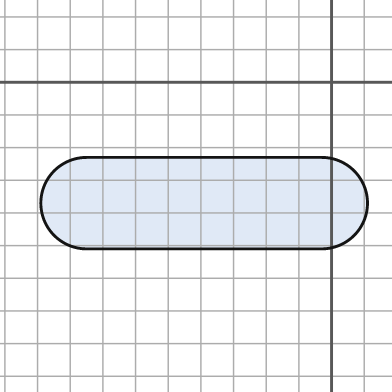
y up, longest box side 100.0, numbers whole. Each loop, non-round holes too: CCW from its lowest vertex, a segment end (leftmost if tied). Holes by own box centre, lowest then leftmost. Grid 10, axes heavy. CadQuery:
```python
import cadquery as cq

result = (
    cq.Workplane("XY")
    .moveTo(-75.0, -51.0)
    .lineTo(-3.0, -51.0)
    .threePointArc((11.0, -37.0), (-3.0, -23.0))
    .lineTo(-75.0, -23.0)
    .threePointArc((-89.0, -37.0), (-75.0, -51.0))
    .close()
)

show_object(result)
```